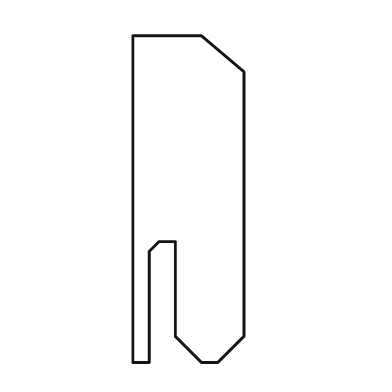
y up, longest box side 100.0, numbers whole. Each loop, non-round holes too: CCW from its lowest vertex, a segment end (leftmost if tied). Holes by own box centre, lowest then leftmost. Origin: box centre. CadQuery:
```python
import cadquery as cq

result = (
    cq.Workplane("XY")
    .moveTo(-17.0, -50.0)
    .lineTo(-12.0, -50.0)
    .lineTo(-12.0, -16.0)
    .lineTo(-9.0, -13.0)
    .lineTo(-4.0, -13.0)
    .lineTo(-4.0, -42.0)
    .lineTo(4.0, -50.0)
    .lineTo(9.0, -50.0)
    .lineTo(17.0, -42.0)
    .lineTo(17.0, 39.0)
    .lineTo(4.0, 50.0)
    .lineTo(-17.0, 50.0)
    .close()
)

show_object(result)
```